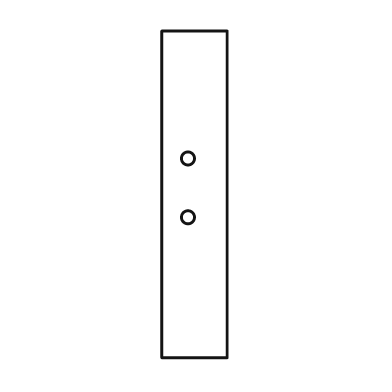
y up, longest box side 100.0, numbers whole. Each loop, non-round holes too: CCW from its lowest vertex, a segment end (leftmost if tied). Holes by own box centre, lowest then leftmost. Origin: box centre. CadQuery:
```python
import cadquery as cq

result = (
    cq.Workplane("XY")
    .moveTo(-10.0, -50.0)
    .lineTo(10.0, -50.0)
    .lineTo(10.0, 50.0)
    .lineTo(-10.0, 50.0)
    .close()
    .moveTo(-2.0, -7.0)
    .circle(2.0)
    .moveTo(-2.0, 11.0)
    .circle(2.0)
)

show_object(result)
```